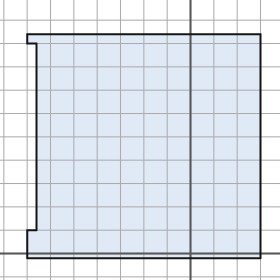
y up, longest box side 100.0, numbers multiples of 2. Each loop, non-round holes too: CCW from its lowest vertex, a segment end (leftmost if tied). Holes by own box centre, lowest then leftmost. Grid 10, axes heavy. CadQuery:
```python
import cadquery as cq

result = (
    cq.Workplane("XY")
    .moveTo(-70.0, -2.0)
    .lineTo(30.0, -2.0)
    .lineTo(30.0, 94.0)
    .lineTo(-70.0, 94.0)
    .lineTo(-70.0, 90.0)
    .lineTo(-66.0, 90.0)
    .lineTo(-66.0, 10.0)
    .lineTo(-70.0, 10.0)
    .close()
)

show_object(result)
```